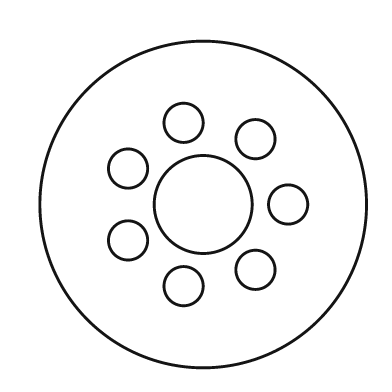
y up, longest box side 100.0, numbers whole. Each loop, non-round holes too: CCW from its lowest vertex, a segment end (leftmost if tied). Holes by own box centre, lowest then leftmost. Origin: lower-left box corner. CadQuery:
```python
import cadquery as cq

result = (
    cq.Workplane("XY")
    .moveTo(50.0, 50.0)
    .circle(50.0)
    .moveTo(44.0, 25.0)
    .circle(6.0)
    .moveTo(66.0, 30.0)
    .circle(6.0)
    .moveTo(27.0, 39.0)
    .circle(6.0)
    .moveTo(50.0, 50.0)
    .circle(15.0)
    .moveTo(76.0, 50.0)
    .circle(6.0)
    .moveTo(27.0, 61.0)
    .circle(6.0)
    .moveTo(66.0, 70.0)
    .circle(6.0)
    .moveTo(44.0, 75.0)
    .circle(6.0)
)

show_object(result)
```